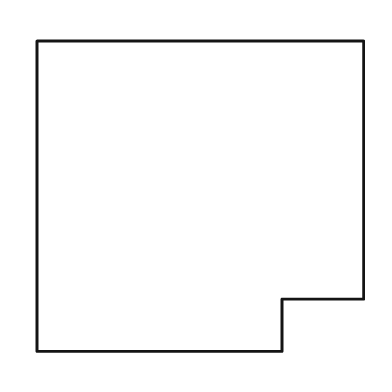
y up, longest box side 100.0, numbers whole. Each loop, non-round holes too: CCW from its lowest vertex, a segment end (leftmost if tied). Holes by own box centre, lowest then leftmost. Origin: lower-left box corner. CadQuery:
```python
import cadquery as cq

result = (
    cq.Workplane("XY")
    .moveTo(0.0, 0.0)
    .lineTo(75.0, 0.0)
    .lineTo(75.0, 16.0)
    .lineTo(100.0, 16.0)
    .lineTo(100.0, 95.0)
    .lineTo(0.0, 95.0)
    .close()
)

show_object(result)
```